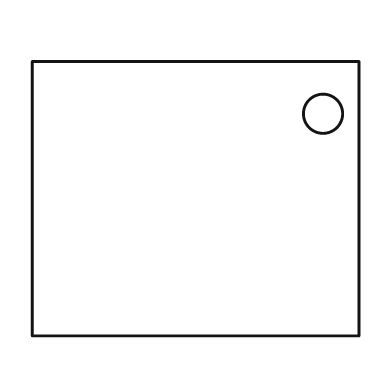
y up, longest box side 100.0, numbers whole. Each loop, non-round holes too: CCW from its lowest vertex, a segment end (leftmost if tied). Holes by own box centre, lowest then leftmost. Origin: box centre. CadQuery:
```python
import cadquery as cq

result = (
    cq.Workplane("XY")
    .moveTo(-50.0, -42.0)
    .lineTo(50.0, -42.0)
    .lineTo(50.0, 42.0)
    .lineTo(-50.0, 42.0)
    .close()
    .moveTo(39.0, 26.0)
    .circle(6.0)
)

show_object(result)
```